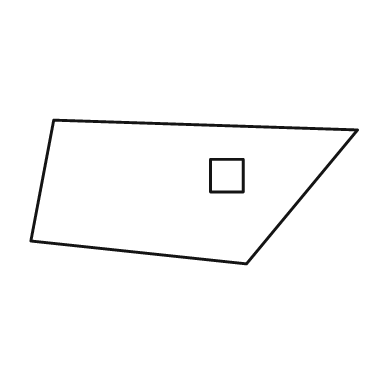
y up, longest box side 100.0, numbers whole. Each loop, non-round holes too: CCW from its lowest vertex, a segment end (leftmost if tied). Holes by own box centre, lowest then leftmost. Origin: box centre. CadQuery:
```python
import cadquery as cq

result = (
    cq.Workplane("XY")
    .moveTo(16.0, -22.0)
    .lineTo(50.0, 19.0)
    .lineTo(-43.0, 22.0)
    .lineTo(-50.0, -15.0)
    .close()
    .moveTo(5.0, 0.0)
    .lineTo(15.0, 0.0)
    .lineTo(15.0, 10.0)
    .lineTo(5.0, 10.0)
    .close()
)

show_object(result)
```